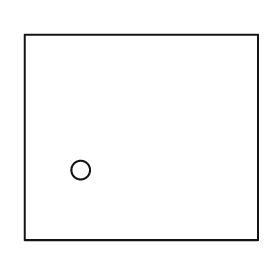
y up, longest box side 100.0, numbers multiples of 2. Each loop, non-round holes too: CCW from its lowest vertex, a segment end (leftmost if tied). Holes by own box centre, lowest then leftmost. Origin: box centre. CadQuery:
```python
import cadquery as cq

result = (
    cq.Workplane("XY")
    .moveTo(-50.0, -44.0)
    .lineTo(50.0, -44.0)
    .lineTo(50.0, 44.0)
    .lineTo(-50.0, 44.0)
    .close()
    .moveTo(-26.0, -14.0)
    .circle(4.0)
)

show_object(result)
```